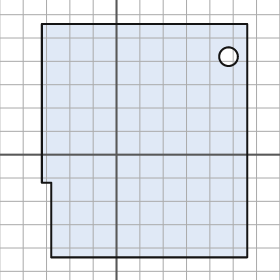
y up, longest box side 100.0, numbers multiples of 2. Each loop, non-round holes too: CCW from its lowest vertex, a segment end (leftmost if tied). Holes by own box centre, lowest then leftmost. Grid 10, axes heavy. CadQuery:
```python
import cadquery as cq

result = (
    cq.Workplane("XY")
    .moveTo(-28.0, -44.0)
    .lineTo(56.0, -44.0)
    .lineTo(56.0, 56.0)
    .lineTo(-32.0, 56.0)
    .lineTo(-32.0, -12.0)
    .lineTo(-28.0, -12.0)
    .close()
    .moveTo(48.0, 42.0)
    .circle(4.0)
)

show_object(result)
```